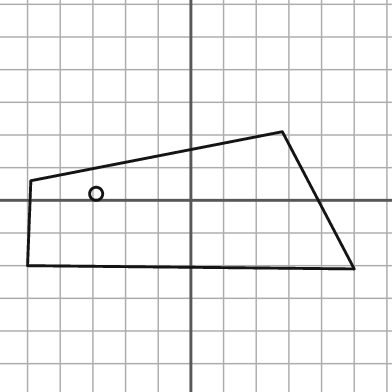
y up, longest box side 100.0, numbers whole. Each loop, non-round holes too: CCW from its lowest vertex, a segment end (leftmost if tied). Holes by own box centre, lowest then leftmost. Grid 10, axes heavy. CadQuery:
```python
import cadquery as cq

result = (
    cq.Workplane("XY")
    .moveTo(50.0, -21.0)
    .lineTo(28.0, 21.0)
    .lineTo(-49.0, 6.0)
    .lineTo(-50.0, -20.0)
    .close()
    .moveTo(-29.0, 2.0)
    .circle(2.0)
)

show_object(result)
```